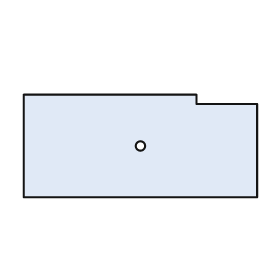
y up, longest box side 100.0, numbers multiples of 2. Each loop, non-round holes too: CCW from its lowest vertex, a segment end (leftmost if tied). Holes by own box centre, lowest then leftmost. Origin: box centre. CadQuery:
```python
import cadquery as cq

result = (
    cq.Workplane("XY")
    .moveTo(-50.0, -22.0)
    .lineTo(50.0, -22.0)
    .lineTo(50.0, 18.0)
    .lineTo(24.0, 18.0)
    .lineTo(24.0, 22.0)
    .lineTo(-50.0, 22.0)
    .close()
    .moveTo(0.0, 0.0)
    .circle(2.0)
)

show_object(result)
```